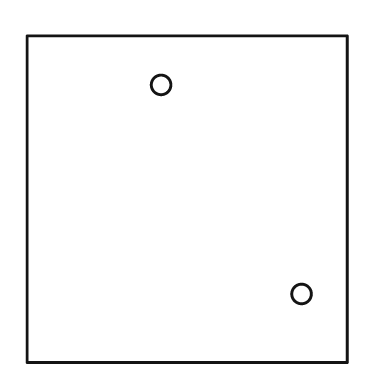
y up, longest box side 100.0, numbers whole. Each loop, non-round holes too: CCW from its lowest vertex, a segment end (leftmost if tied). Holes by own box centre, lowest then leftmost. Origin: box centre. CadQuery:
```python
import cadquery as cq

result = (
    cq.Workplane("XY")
    .moveTo(-49.0, -50.0)
    .lineTo(49.0, -50.0)
    .lineTo(49.0, 50.0)
    .lineTo(-49.0, 50.0)
    .close()
    .moveTo(35.0, -29.0)
    .circle(3.0)
    .moveTo(-8.0, 35.0)
    .circle(3.0)
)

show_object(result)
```